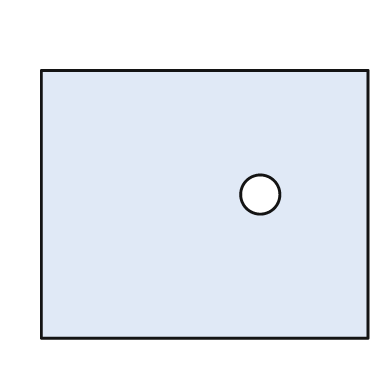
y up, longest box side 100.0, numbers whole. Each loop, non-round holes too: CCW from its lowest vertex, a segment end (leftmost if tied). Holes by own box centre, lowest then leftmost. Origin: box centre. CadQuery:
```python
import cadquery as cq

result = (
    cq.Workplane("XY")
    .moveTo(-50.0, -41.0)
    .lineTo(50.0, -41.0)
    .lineTo(50.0, 41.0)
    .lineTo(-50.0, 41.0)
    .close()
    .moveTo(17.0, 3.0)
    .circle(6.0)
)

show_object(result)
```